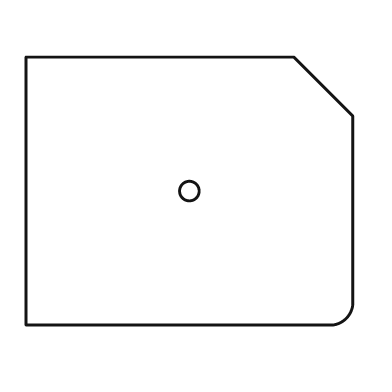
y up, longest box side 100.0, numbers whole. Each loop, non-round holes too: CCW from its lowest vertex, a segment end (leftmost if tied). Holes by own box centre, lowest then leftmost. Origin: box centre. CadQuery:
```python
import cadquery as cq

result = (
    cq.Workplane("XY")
    .moveTo(-50.0, -41.0)
    .lineTo(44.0, -41.0)
    .threePointArc((48.0, -39.0), (50.0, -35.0))
    .lineTo(50.0, 23.0)
    .lineTo(32.0, 41.0)
    .lineTo(-50.0, 41.0)
    .close()
    .moveTo(0.0, 0.0)
    .circle(3.0)
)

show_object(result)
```